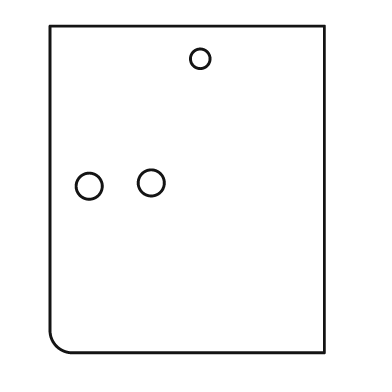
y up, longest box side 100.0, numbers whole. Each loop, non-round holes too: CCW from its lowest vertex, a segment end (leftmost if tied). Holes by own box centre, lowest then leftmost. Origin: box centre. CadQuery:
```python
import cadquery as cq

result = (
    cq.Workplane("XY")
    .moveTo(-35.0, -50.0)
    .lineTo(42.0, -50.0)
    .lineTo(42.0, 50.0)
    .lineTo(-42.0, 50.0)
    .lineTo(-42.0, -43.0)
    .threePointArc((-40.0, -48.0), (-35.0, -50.0))
    .close()
    .moveTo(-30.0, 1.0)
    .circle(4.0)
    .moveTo(-11.0, 2.0)
    .circle(4.0)
    .moveTo(4.0, 40.0)
    .circle(3.0)
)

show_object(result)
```